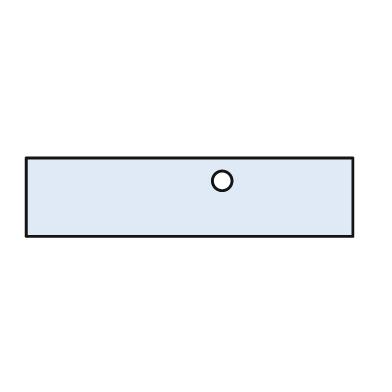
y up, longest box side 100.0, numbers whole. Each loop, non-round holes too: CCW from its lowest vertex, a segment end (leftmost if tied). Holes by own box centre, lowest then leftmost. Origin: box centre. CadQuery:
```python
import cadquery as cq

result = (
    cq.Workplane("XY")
    .moveTo(-50.0, -12.0)
    .lineTo(50.0, -12.0)
    .lineTo(50.0, 12.0)
    .lineTo(-50.0, 12.0)
    .close()
    .moveTo(10.0, 5.0)
    .circle(3.0)
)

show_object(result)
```